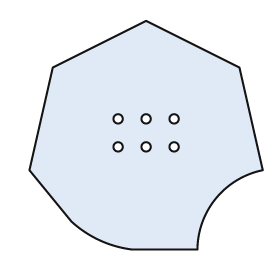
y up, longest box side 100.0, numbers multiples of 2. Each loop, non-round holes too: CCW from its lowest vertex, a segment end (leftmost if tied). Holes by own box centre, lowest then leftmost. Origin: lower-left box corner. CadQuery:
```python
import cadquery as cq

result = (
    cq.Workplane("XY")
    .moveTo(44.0, 0.0)
    .lineTo(72.0, 0.0)
    .threePointArc((80.0, 22.0), (100.0, 34.0))
    .lineTo(90.0, 78.0)
    .lineTo(50.0, 98.0)
    .lineTo(10.0, 78.0)
    .lineTo(0.0, 34.0)
    .lineTo(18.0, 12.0)
    .threePointArc((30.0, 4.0), (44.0, 0.0))
    .close()
    .moveTo(38.0, 44.0)
    .circle(2.0)
    .moveTo(50.0, 44.0)
    .circle(2.0)
    .moveTo(62.0, 44.0)
    .circle(2.0)
    .moveTo(38.0, 56.0)
    .circle(2.0)
    .moveTo(50.0, 56.0)
    .circle(2.0)
    .moveTo(62.0, 56.0)
    .circle(2.0)
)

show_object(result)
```